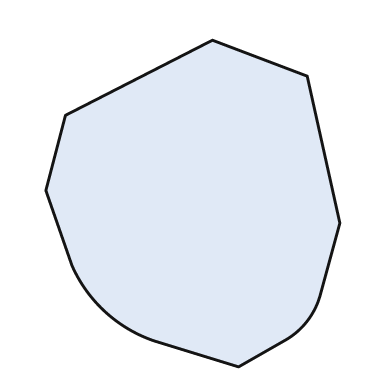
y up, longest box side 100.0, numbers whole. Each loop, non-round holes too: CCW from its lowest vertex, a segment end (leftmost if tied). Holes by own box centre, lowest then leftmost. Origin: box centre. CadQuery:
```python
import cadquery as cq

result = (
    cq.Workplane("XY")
    .moveTo(14.0, -50.0)
    .lineTo(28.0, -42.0)
    .threePointArc((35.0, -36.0), (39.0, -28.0))
    .lineTo(45.0, -6.0)
    .lineTo(35.0, 39.0)
    .lineTo(6.0, 50.0)
    .lineTo(-39.0, 27.0)
    .lineTo(-45.0, 4.0)
    .lineTo(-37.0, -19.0)
    .threePointArc((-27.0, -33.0), (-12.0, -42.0))
    .close()
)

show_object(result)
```